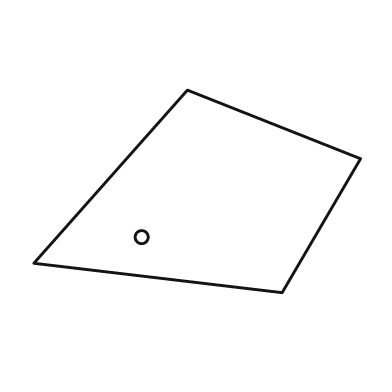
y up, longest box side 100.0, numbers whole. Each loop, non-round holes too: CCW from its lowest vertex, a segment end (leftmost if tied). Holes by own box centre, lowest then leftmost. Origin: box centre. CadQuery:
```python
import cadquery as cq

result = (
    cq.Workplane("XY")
    .moveTo(26.0, -31.0)
    .lineTo(50.0, 10.0)
    .lineTo(-3.0, 31.0)
    .lineTo(-50.0, -22.0)
    .close()
    .moveTo(-17.0, -14.0)
    .circle(2.0)
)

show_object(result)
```